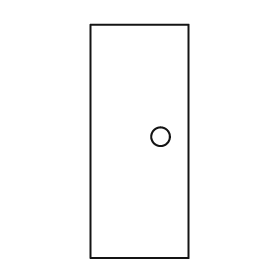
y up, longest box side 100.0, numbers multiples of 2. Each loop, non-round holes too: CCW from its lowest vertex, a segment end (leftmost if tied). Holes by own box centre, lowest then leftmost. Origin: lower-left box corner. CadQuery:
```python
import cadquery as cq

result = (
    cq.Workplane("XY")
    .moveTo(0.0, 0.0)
    .lineTo(42.0, 0.0)
    .lineTo(42.0, 100.0)
    .lineTo(0.0, 100.0)
    .close()
    .moveTo(30.0, 52.0)
    .circle(4.0)
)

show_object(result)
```